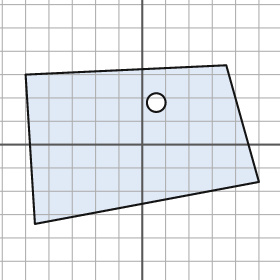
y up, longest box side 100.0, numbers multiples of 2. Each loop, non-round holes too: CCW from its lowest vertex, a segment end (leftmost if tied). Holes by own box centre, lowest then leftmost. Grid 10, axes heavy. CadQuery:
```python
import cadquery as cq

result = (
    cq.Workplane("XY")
    .moveTo(-46.0, -34.0)
    .lineTo(50.0, -16.0)
    .lineTo(36.0, 34.0)
    .lineTo(-50.0, 30.0)
    .close()
    .moveTo(6.0, 18.0)
    .circle(4.0)
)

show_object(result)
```